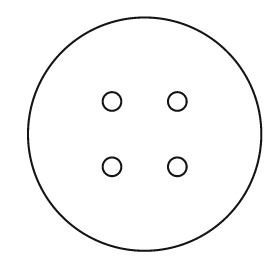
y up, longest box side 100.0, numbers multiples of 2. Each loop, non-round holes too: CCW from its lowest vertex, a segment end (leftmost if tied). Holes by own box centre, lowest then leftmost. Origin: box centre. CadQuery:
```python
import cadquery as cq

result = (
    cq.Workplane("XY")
    .moveTo(0.0, 0.0)
    .circle(50.0)
    .moveTo(-14.0, -14.0)
    .circle(4.0)
    .moveTo(14.0, -14.0)
    .circle(4.0)
    .moveTo(-14.0, 14.0)
    .circle(4.0)
    .moveTo(14.0, 14.0)
    .circle(4.0)
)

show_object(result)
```